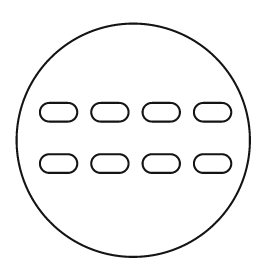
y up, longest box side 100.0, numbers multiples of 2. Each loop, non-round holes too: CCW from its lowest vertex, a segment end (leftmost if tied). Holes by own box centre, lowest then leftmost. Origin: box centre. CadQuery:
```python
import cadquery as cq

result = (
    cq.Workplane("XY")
    .moveTo(0.0, 0.0)
    .circle(50.0)
    .moveTo(-36.0, -14.0)
    .lineTo(-28.0, -14.0)
    .threePointArc((-24.0, -10.0), (-28.0, -6.0))
    .lineTo(-36.0, -6.0)
    .threePointArc((-40.0, -10.0), (-36.0, -14.0))
    .close()
    .moveTo(-14.0, -14.0)
    .lineTo(-6.0, -14.0)
    .threePointArc((-2.0, -10.0), (-6.0, -6.0))
    .lineTo(-14.0, -6.0)
    .threePointArc((-18.0, -10.0), (-14.0, -14.0))
    .close()
    .moveTo(8.0, -14.0)
    .lineTo(16.0, -14.0)
    .threePointArc((20.0, -10.0), (16.0, -6.0))
    .lineTo(8.0, -6.0)
    .threePointArc((4.0, -10.0), (8.0, -14.0))
    .close()
    .moveTo(30.0, -14.0)
    .lineTo(38.0, -14.0)
    .threePointArc((42.0, -10.0), (38.0, -6.0))
    .lineTo(30.0, -6.0)
    .threePointArc((26.0, -10.0), (30.0, -14.0))
    .close()
    .moveTo(-36.0, 8.0)
    .lineTo(-28.0, 8.0)
    .threePointArc((-24.0, 12.0), (-28.0, 16.0))
    .lineTo(-36.0, 16.0)
    .threePointArc((-40.0, 12.0), (-36.0, 8.0))
    .close()
    .moveTo(-14.0, 8.0)
    .lineTo(-6.0, 8.0)
    .threePointArc((-2.0, 12.0), (-6.0, 16.0))
    .lineTo(-14.0, 16.0)
    .threePointArc((-18.0, 12.0), (-14.0, 8.0))
    .close()
    .moveTo(8.0, 8.0)
    .lineTo(16.0, 8.0)
    .threePointArc((20.0, 12.0), (16.0, 16.0))
    .lineTo(8.0, 16.0)
    .threePointArc((4.0, 12.0), (8.0, 8.0))
    .close()
    .moveTo(30.0, 8.0)
    .lineTo(38.0, 8.0)
    .threePointArc((42.0, 12.0), (38.0, 16.0))
    .lineTo(30.0, 16.0)
    .threePointArc((26.0, 12.0), (30.0, 8.0))
    .close()
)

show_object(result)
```